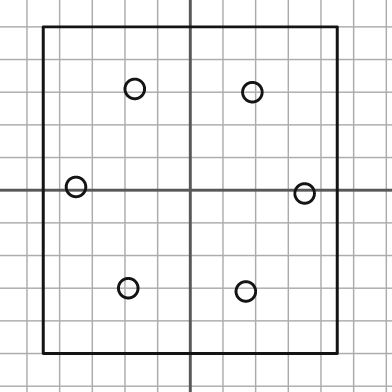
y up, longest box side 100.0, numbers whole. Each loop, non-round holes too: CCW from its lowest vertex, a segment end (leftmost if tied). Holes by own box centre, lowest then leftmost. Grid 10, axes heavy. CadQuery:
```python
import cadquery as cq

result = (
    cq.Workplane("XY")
    .moveTo(-45.0, -50.0)
    .lineTo(45.0, -50.0)
    .lineTo(45.0, 50.0)
    .lineTo(-45.0, 50.0)
    .close()
    .moveTo(17.0, -31.0)
    .circle(3.0)
    .moveTo(-19.0, -30.0)
    .circle(3.0)
    .moveTo(35.0, -1.0)
    .circle(3.0)
    .moveTo(-35.0, 1.0)
    .circle(3.0)
    .moveTo(19.0, 30.0)
    .circle(3.0)
    .moveTo(-17.0, 31.0)
    .circle(3.0)
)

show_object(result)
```